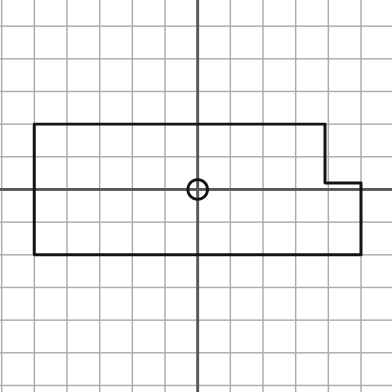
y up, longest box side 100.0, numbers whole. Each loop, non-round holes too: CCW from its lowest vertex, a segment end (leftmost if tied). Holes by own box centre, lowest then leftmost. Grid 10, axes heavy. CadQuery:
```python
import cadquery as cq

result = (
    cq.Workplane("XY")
    .moveTo(-50.0, -20.0)
    .lineTo(50.0, -20.0)
    .lineTo(50.0, 2.0)
    .lineTo(39.0, 2.0)
    .lineTo(39.0, 20.0)
    .lineTo(-50.0, 20.0)
    .close()
    .moveTo(0.0, 0.0)
    .circle(3.0)
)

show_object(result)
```